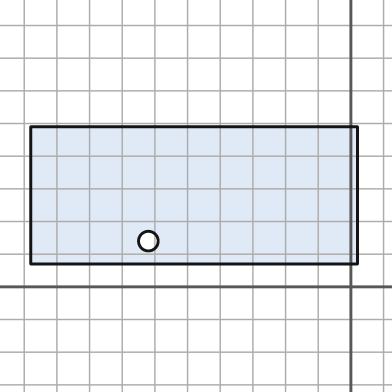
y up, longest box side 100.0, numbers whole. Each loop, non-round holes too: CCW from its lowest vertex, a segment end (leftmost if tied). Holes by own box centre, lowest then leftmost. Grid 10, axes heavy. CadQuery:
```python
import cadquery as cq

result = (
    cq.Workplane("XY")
    .moveTo(-98.0, 7.0)
    .lineTo(2.0, 7.0)
    .lineTo(2.0, 49.0)
    .lineTo(-98.0, 49.0)
    .close()
    .moveTo(-62.0, 14.0)
    .circle(3.0)
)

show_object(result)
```